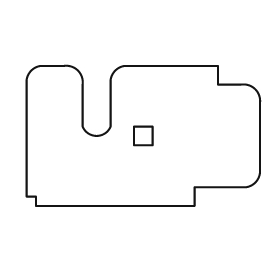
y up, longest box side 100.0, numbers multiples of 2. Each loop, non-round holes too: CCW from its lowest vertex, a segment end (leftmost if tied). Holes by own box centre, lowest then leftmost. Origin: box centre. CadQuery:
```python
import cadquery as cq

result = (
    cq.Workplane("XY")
    .moveTo(-46.0, -30.0)
    .lineTo(22.0, -30.0)
    .lineTo(22.0, -22.0)
    .lineTo(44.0, -22.0)
    .threePointArc((48.0, -20.0), (50.0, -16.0))
    .lineTo(50.0, 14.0)
    .threePointArc((48.0, 20.0), (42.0, 22.0))
    .lineTo(32.0, 22.0)
    .lineTo(32.0, 30.0)
    .lineTo(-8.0, 30.0)
    .threePointArc((-12.0, 28.0), (-14.0, 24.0))
    .lineTo(-14.0, 4.0)
    .threePointArc((-20.0, 0.0), (-26.0, 4.0))
    .lineTo(-26.0, 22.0)
    .threePointArc((-28.0, 28.0), (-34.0, 30.0))
    .lineTo(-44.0, 30.0)
    .threePointArc((-48.0, 28.0), (-50.0, 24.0))
    .lineTo(-50.0, -26.0)
    .lineTo(-46.0, -26.0)
    .close()
    .moveTo(-4.0, -4.0)
    .lineTo(4.0, -4.0)
    .lineTo(4.0, 4.0)
    .lineTo(-4.0, 4.0)
    .close()
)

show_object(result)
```